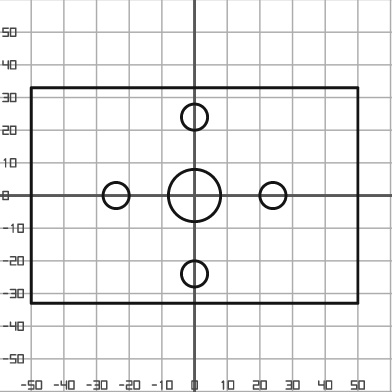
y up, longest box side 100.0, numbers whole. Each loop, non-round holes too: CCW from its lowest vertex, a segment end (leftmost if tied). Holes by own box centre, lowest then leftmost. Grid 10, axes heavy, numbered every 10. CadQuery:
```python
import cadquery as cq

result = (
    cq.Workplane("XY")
    .moveTo(-50.0, -33.0)
    .lineTo(50.0, -33.0)
    .lineTo(50.0, 33.0)
    .lineTo(-50.0, 33.0)
    .close()
    .moveTo(0.0, -24.0)
    .circle(4.0)
    .moveTo(-24.0, 0.0)
    .circle(4.0)
    .moveTo(0.0, 0.0)
    .circle(8.0)
    .moveTo(24.0, 0.0)
    .circle(4.0)
    .moveTo(0.0, 24.0)
    .circle(4.0)
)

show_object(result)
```